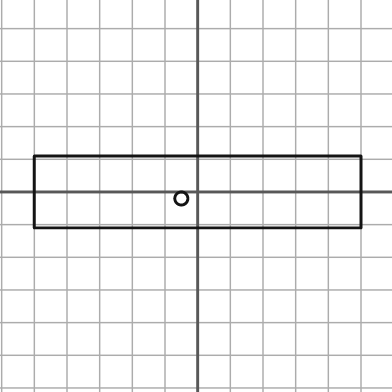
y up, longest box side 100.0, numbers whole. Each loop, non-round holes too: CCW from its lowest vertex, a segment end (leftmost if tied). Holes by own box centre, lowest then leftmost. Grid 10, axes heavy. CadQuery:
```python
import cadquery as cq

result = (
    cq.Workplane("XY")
    .moveTo(-50.0, -11.0)
    .lineTo(50.0, -11.0)
    .lineTo(50.0, 11.0)
    .lineTo(-50.0, 11.0)
    .close()
    .moveTo(-5.0, -2.0)
    .circle(2.0)
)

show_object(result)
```